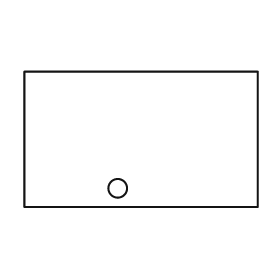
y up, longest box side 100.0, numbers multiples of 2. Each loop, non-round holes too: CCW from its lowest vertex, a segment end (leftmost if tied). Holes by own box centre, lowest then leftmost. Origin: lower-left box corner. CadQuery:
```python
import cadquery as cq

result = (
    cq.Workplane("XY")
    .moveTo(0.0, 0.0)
    .lineTo(100.0, 0.0)
    .lineTo(100.0, 58.0)
    .lineTo(0.0, 58.0)
    .close()
    .moveTo(40.0, 8.0)
    .circle(4.0)
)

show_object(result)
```